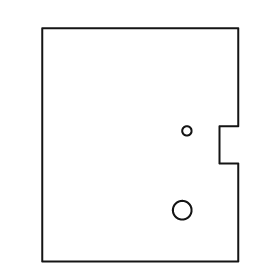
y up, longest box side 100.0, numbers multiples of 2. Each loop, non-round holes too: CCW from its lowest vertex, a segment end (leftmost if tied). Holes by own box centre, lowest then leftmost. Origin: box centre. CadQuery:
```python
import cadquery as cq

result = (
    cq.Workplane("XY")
    .moveTo(-42.0, -50.0)
    .lineTo(42.0, -50.0)
    .lineTo(42.0, -8.0)
    .lineTo(34.0, -8.0)
    .lineTo(34.0, 8.0)
    .lineTo(42.0, 8.0)
    .lineTo(42.0, 50.0)
    .lineTo(-42.0, 50.0)
    .close()
    .moveTo(18.0, -28.0)
    .circle(4.0)
    .moveTo(20.0, 6.0)
    .circle(2.0)
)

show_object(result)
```